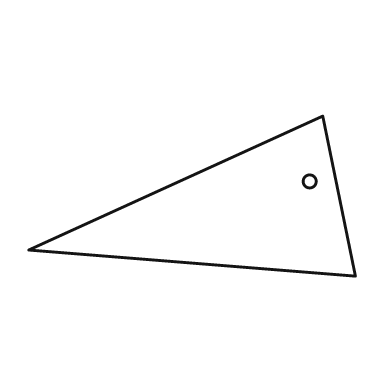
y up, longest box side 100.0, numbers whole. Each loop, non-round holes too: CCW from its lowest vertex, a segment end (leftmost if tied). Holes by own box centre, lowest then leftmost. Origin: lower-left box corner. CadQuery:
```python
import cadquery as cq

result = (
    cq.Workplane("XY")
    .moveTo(100.0, 0.0)
    .lineTo(90.0, 49.0)
    .lineTo(0.0, 8.0)
    .close()
    .moveTo(86.0, 29.0)
    .circle(2.0)
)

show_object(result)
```